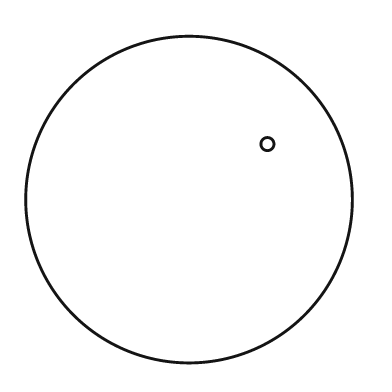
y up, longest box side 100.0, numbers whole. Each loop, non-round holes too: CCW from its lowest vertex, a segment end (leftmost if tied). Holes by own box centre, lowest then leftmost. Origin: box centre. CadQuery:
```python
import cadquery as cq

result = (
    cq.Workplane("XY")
    .moveTo(0.0, 0.0)
    .circle(50.0)
    .moveTo(24.0, 17.0)
    .circle(2.0)
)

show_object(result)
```